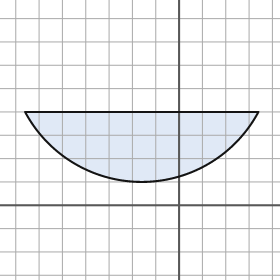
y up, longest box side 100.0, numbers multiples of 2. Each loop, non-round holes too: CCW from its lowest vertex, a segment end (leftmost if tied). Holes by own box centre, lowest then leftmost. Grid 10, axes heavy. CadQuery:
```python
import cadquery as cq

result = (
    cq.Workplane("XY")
    .moveTo(-66.0, 40.0)
    .threePointArc((-16.0, 10.0), (34.0, 40.0))
    .close()
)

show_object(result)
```